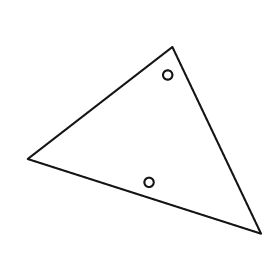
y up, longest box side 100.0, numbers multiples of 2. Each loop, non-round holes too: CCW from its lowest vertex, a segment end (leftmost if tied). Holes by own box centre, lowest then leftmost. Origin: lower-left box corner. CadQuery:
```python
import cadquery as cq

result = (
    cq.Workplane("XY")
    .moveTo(100.0, 0.0)
    .lineTo(62.0, 80.0)
    .lineTo(0.0, 32.0)
    .close()
    .moveTo(52.0, 22.0)
    .circle(2.0)
    .moveTo(60.0, 68.0)
    .circle(2.0)
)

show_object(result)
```